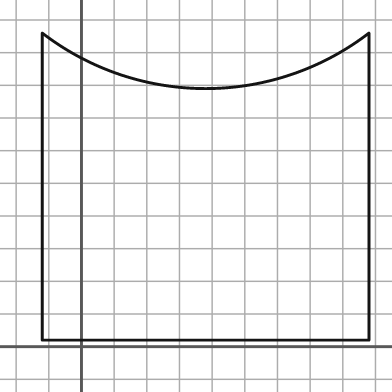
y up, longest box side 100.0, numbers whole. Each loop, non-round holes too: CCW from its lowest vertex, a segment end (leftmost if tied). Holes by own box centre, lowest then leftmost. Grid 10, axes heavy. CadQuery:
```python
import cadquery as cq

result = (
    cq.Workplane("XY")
    .moveTo(-12.0, 2.0)
    .lineTo(88.0, 2.0)
    .lineTo(88.0, 96.0)
    .threePointArc((38.0, 79.0), (-12.0, 96.0))
    .close()
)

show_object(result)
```